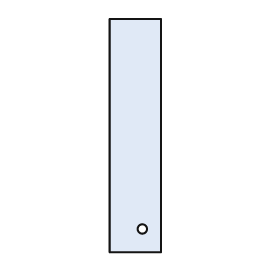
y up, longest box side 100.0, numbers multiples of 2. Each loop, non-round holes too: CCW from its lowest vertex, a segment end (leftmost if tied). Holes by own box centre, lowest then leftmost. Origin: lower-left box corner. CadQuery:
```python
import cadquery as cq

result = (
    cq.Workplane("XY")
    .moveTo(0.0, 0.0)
    .lineTo(22.0, 0.0)
    .lineTo(22.0, 100.0)
    .lineTo(0.0, 100.0)
    .close()
    .moveTo(14.0, 10.0)
    .circle(2.0)
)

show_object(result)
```